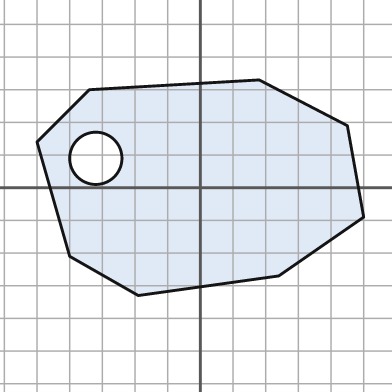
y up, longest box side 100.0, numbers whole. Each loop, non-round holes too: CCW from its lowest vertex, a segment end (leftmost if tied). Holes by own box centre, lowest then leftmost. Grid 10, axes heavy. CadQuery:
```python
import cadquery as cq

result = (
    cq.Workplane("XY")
    .moveTo(-19.0, -33.0)
    .lineTo(24.0, -27.0)
    .lineTo(50.0, -9.0)
    .lineTo(45.0, 19.0)
    .lineTo(18.0, 33.0)
    .lineTo(-34.0, 30.0)
    .lineTo(-50.0, 14.0)
    .lineTo(-40.0, -21.0)
    .close()
    .moveTo(-32.0, 9.0)
    .circle(8.0)
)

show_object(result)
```